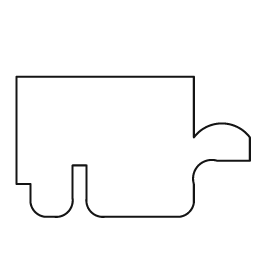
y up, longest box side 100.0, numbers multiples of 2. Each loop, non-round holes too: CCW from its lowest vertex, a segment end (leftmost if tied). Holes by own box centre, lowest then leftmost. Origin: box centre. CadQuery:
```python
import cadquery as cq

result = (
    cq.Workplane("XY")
    .moveTo(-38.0, -30.0)
    .lineTo(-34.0, -30.0)
    .threePointArc((-28.0, -28.0), (-26.0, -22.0))
    .lineTo(-26.0, -8.0)
    .lineTo(-20.0, -8.0)
    .lineTo(-20.0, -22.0)
    .threePointArc((-18.0, -28.0), (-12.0, -30.0))
    .lineTo(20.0, -30.0)
    .threePointArc((24.0, -28.0), (26.0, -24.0))
    .lineTo(26.0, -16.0)
    .threePointArc((28.0, -8.0), (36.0, -6.0))
    .lineTo(50.0, -6.0)
    .lineTo(50.0, 4.0)
    .threePointArc((38.0, 10.0), (26.0, 4.0))
    .lineTo(26.0, 30.0)
    .lineTo(-50.0, 30.0)
    .lineTo(-50.0, -16.0)
    .lineTo(-44.0, -16.0)
    .lineTo(-44.0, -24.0)
    .threePointArc((-42.0, -28.0), (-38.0, -30.0))
    .close()
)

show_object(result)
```